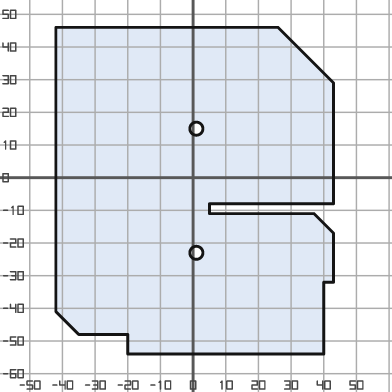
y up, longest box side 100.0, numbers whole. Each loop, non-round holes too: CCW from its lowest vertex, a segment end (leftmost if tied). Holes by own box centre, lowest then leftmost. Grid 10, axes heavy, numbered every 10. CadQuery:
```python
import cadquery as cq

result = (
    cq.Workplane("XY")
    .moveTo(-20.0, -54.0)
    .lineTo(40.0, -54.0)
    .lineTo(40.0, -32.0)
    .lineTo(43.0, -32.0)
    .lineTo(43.0, -17.0)
    .lineTo(37.0, -11.0)
    .lineTo(5.0, -11.0)
    .lineTo(5.0, -8.0)
    .lineTo(43.0, -8.0)
    .lineTo(43.0, 29.0)
    .lineTo(26.0, 46.0)
    .lineTo(-42.0, 46.0)
    .lineTo(-42.0, -41.0)
    .lineTo(-35.0, -48.0)
    .lineTo(-20.0, -48.0)
    .close()
    .moveTo(1.0, -23.0)
    .circle(2.0)
    .moveTo(1.0, 15.0)
    .circle(2.0)
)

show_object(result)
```